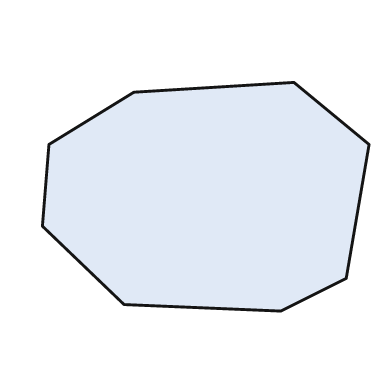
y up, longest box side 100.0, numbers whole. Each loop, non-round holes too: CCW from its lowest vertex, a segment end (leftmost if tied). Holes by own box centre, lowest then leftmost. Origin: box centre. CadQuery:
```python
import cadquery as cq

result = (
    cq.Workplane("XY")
    .moveTo(23.0, -35.0)
    .lineTo(43.0, -25.0)
    .lineTo(50.0, 16.0)
    .lineTo(27.0, 35.0)
    .lineTo(-22.0, 32.0)
    .lineTo(-48.0, 16.0)
    .lineTo(-50.0, -9.0)
    .lineTo(-25.0, -33.0)
    .close()
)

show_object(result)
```